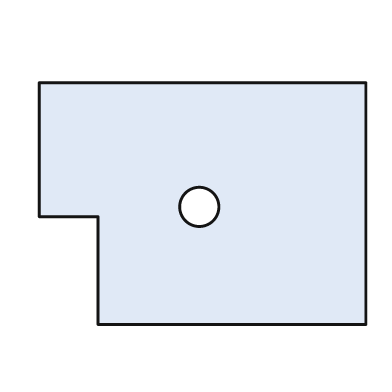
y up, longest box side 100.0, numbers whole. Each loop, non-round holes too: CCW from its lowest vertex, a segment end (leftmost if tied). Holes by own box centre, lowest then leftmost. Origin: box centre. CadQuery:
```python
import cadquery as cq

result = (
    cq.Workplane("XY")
    .moveTo(-32.0, -37.0)
    .lineTo(50.0, -37.0)
    .lineTo(50.0, 37.0)
    .lineTo(-50.0, 37.0)
    .lineTo(-50.0, -4.0)
    .lineTo(-32.0, -4.0)
    .close()
    .moveTo(-1.0, -1.0)
    .circle(6.0)
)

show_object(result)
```